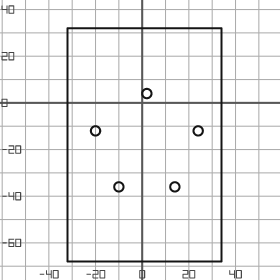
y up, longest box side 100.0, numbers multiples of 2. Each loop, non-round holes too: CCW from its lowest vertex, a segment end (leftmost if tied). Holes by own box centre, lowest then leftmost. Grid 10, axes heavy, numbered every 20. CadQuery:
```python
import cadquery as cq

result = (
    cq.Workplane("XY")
    .moveTo(-32.0, -68.0)
    .lineTo(34.0, -68.0)
    .lineTo(34.0, 32.0)
    .lineTo(-32.0, 32.0)
    .close()
    .moveTo(-10.0, -36.0)
    .circle(2.0)
    .moveTo(14.0, -36.0)
    .circle(2.0)
    .moveTo(-20.0, -12.0)
    .circle(2.0)
    .moveTo(24.0, -12.0)
    .circle(2.0)
    .moveTo(2.0, 4.0)
    .circle(2.0)
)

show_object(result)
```